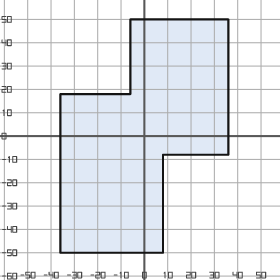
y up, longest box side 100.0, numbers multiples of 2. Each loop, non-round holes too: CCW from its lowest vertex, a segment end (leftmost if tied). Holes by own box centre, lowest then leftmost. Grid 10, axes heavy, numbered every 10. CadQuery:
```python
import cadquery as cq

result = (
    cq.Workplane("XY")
    .moveTo(-36.0, -50.0)
    .lineTo(8.0, -50.0)
    .lineTo(8.0, -8.0)
    .lineTo(36.0, -8.0)
    .lineTo(36.0, 50.0)
    .lineTo(-6.0, 50.0)
    .lineTo(-6.0, 18.0)
    .lineTo(-36.0, 18.0)
    .close()
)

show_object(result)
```